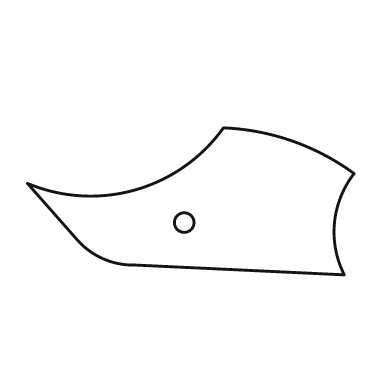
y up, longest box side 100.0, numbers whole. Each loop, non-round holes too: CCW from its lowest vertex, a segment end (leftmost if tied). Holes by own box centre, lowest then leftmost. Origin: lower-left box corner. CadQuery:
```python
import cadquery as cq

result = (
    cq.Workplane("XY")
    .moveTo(97.0, 0.0)
    .threePointArc((94.0, 16.0), (100.0, 31.0))
    .threePointArc((81.0, 41.0), (60.0, 45.0))
    .threePointArc((33.0, 26.0), (0.0, 28.0))
    .lineTo(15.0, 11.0)
    .threePointArc((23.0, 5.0), (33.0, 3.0))
    .close()
    .moveTo(48.0, 16.0)
    .circle(3.0)
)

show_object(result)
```